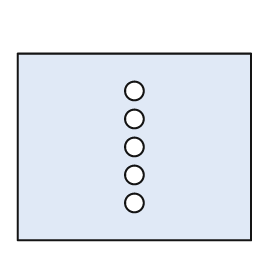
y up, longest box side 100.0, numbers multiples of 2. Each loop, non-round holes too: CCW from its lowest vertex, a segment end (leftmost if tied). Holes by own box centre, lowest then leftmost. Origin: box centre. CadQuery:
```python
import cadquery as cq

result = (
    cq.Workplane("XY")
    .moveTo(-50.0, -40.0)
    .lineTo(50.0, -40.0)
    .lineTo(50.0, 40.0)
    .lineTo(-50.0, 40.0)
    .close()
    .moveTo(0.0, -24.0)
    .circle(4.0)
    .moveTo(0.0, -12.0)
    .circle(4.0)
    .moveTo(0.0, 0.0)
    .circle(4.0)
    .moveTo(0.0, 12.0)
    .circle(4.0)
    .moveTo(0.0, 24.0)
    .circle(4.0)
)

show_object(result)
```